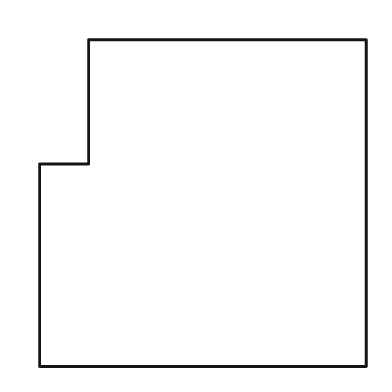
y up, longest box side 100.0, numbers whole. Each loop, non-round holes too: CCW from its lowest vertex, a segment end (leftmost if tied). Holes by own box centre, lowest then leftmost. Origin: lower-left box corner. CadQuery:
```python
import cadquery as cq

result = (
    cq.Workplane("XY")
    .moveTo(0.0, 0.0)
    .lineTo(100.0, 0.0)
    .lineTo(100.0, 100.0)
    .lineTo(15.0, 100.0)
    .lineTo(15.0, 62.0)
    .lineTo(0.0, 62.0)
    .close()
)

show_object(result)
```